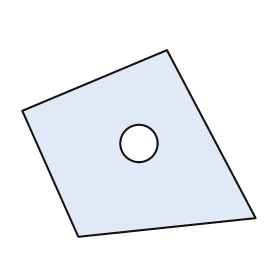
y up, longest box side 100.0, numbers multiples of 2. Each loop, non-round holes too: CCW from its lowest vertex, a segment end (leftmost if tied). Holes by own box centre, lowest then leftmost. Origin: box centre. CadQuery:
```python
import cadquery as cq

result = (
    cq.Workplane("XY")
    .moveTo(-26.0, -40.0)
    .lineTo(50.0, -32.0)
    .lineTo(12.0, 40.0)
    .lineTo(-50.0, 14.0)
    .close()
    .moveTo(0.0, 0.0)
    .circle(8.0)
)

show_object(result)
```